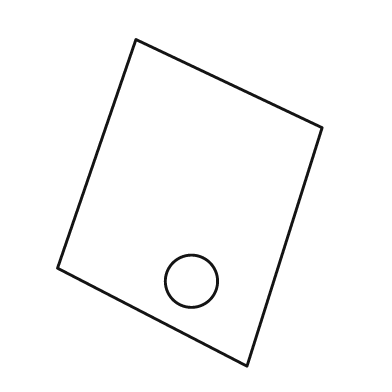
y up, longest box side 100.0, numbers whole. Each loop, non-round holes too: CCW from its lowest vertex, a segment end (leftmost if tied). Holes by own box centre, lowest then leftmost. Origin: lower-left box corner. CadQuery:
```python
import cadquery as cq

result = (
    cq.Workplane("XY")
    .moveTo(58.0, 0.0)
    .lineTo(81.0, 73.0)
    .lineTo(24.0, 100.0)
    .lineTo(0.0, 30.0)
    .close()
    .moveTo(41.0, 26.0)
    .circle(8.0)
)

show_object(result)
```